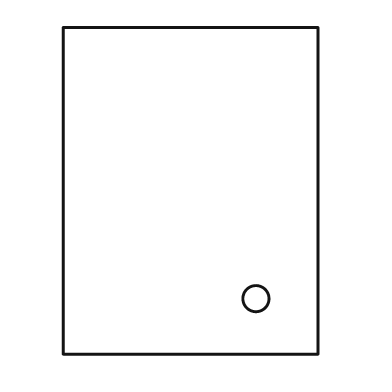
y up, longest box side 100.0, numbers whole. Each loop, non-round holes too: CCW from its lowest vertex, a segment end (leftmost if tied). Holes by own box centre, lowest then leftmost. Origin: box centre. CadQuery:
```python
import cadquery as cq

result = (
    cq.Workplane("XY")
    .moveTo(-39.0, -50.0)
    .lineTo(39.0, -50.0)
    .lineTo(39.0, 50.0)
    .lineTo(-39.0, 50.0)
    .close()
    .moveTo(20.0, -33.0)
    .circle(4.0)
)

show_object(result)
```